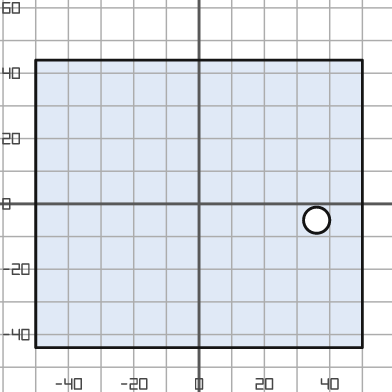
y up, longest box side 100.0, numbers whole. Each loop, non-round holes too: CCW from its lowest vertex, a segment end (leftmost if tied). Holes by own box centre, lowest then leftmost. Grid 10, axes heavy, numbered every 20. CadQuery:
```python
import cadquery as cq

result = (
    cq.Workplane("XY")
    .moveTo(-50.0, -44.0)
    .lineTo(50.0, -44.0)
    .lineTo(50.0, 44.0)
    .lineTo(-50.0, 44.0)
    .close()
    .moveTo(36.0, -5.0)
    .circle(4.0)
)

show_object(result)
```